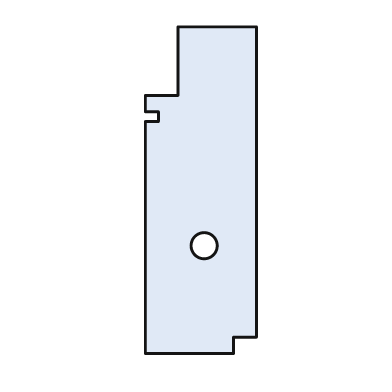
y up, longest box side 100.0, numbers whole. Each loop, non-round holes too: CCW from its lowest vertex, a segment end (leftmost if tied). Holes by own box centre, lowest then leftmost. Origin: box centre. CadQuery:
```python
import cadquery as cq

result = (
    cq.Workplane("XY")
    .moveTo(-17.0, -50.0)
    .lineTo(10.0, -50.0)
    .lineTo(10.0, -45.0)
    .lineTo(17.0, -45.0)
    .lineTo(17.0, 50.0)
    .lineTo(-7.0, 50.0)
    .lineTo(-7.0, 29.0)
    .lineTo(-17.0, 29.0)
    .lineTo(-17.0, 24.0)
    .lineTo(-13.0, 24.0)
    .lineTo(-13.0, 21.0)
    .lineTo(-17.0, 21.0)
    .close()
    .moveTo(1.0, -17.0)
    .circle(4.0)
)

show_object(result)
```